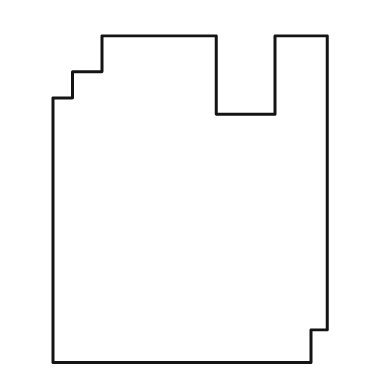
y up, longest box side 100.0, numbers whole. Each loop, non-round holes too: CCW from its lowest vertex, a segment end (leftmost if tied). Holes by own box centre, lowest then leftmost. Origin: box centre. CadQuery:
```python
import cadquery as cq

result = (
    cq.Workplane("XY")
    .moveTo(-42.0, -50.0)
    .lineTo(37.0, -50.0)
    .lineTo(37.0, -40.0)
    .lineTo(42.0, -40.0)
    .lineTo(42.0, 50.0)
    .lineTo(26.0, 50.0)
    .lineTo(26.0, 26.0)
    .lineTo(8.0, 26.0)
    .lineTo(8.0, 50.0)
    .lineTo(-27.0, 50.0)
    .lineTo(-27.0, 39.0)
    .lineTo(-36.0, 39.0)
    .lineTo(-36.0, 31.0)
    .lineTo(-42.0, 31.0)
    .close()
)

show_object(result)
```